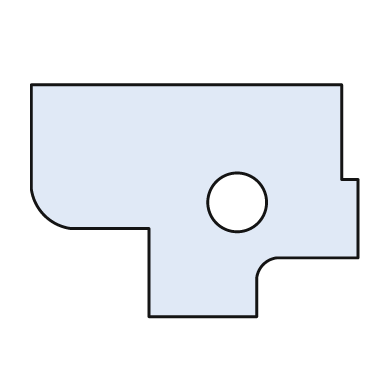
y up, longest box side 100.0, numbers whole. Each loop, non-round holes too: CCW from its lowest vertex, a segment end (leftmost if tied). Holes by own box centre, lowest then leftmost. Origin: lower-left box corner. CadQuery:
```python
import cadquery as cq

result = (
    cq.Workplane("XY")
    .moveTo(36.0, 0.0)
    .lineTo(69.0, 0.0)
    .lineTo(69.0, 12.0)
    .threePointArc((71.0, 16.0), (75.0, 18.0))
    .lineTo(100.0, 18.0)
    .lineTo(100.0, 42.0)
    .lineTo(95.0, 42.0)
    .lineTo(95.0, 71.0)
    .lineTo(0.0, 71.0)
    .lineTo(0.0, 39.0)
    .threePointArc((4.0, 31.0), (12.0, 27.0))
    .lineTo(36.0, 27.0)
    .close()
    .moveTo(63.0, 35.0)
    .circle(9.0)
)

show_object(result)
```